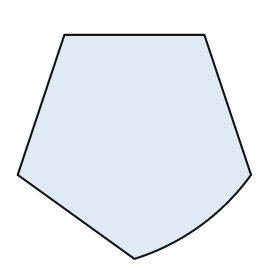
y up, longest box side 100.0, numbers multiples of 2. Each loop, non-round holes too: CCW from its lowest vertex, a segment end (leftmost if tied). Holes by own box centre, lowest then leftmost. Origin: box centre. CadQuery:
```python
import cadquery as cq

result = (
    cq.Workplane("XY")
    .moveTo(0.0, -48.0)
    .threePointArc((28.0, -34.0), (50.0, -12.0))
    .lineTo(30.0, 48.0)
    .lineTo(-30.0, 48.0)
    .lineTo(-50.0, -12.0)
    .close()
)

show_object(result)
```